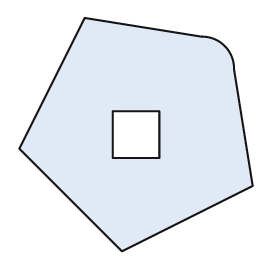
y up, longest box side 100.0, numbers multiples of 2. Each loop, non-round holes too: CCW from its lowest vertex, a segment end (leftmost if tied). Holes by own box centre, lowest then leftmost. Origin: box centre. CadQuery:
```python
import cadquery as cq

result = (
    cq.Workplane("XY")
    .moveTo(-6.0, -50.0)
    .lineTo(50.0, -22.0)
    .lineTo(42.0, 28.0)
    .threePointArc((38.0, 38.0), (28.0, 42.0))
    .lineTo(-22.0, 50.0)
    .lineTo(-50.0, -6.0)
    .close()
    .moveTo(-10.0, -10.0)
    .lineTo(10.0, -10.0)
    .lineTo(10.0, 10.0)
    .lineTo(-10.0, 10.0)
    .close()
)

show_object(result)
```